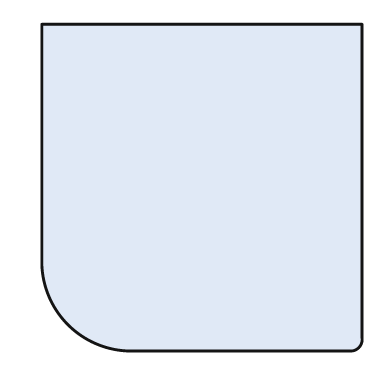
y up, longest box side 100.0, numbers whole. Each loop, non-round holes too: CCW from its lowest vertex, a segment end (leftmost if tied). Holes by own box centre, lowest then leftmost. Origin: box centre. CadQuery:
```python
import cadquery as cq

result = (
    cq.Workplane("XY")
    .moveTo(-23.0, -50.0)
    .lineTo(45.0, -50.0)
    .threePointArc((48.0, -49.0), (49.0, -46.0))
    .lineTo(49.0, 50.0)
    .lineTo(-49.0, 50.0)
    .lineTo(-49.0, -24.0)
    .threePointArc((-41.0, -42.0), (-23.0, -50.0))
    .close()
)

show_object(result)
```